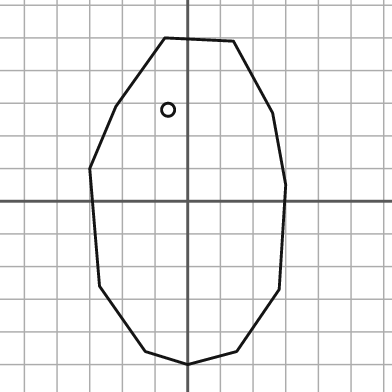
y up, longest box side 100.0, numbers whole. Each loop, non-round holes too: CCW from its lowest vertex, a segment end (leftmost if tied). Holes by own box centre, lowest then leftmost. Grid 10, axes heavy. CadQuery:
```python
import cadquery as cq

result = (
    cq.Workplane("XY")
    .moveTo(0.0, -50.0)
    .lineTo(15.0, -46.0)
    .lineTo(28.0, -27.0)
    .lineTo(30.0, 5.0)
    .lineTo(26.0, 27.0)
    .lineTo(14.0, 49.0)
    .lineTo(-7.0, 50.0)
    .lineTo(-22.0, 29.0)
    .lineTo(-30.0, 10.0)
    .lineTo(-27.0, -26.0)
    .lineTo(-13.0, -46.0)
    .close()
    .moveTo(-6.0, 28.0)
    .circle(2.0)
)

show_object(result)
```